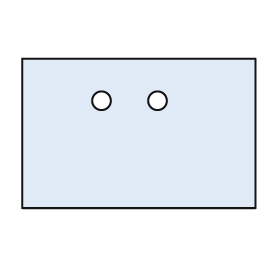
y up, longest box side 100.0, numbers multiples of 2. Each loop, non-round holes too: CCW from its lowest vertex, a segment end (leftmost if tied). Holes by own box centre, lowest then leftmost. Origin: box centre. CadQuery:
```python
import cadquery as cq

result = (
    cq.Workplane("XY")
    .moveTo(-50.0, -32.0)
    .lineTo(50.0, -32.0)
    .lineTo(50.0, 32.0)
    .lineTo(-50.0, 32.0)
    .close()
    .moveTo(-16.0, 14.0)
    .circle(4.0)
    .moveTo(8.0, 14.0)
    .circle(4.0)
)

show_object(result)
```